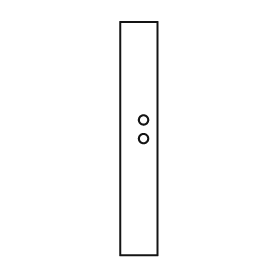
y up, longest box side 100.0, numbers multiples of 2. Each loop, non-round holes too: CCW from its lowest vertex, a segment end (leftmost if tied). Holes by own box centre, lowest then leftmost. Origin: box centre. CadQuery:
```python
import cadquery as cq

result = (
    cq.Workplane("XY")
    .moveTo(-8.0, -50.0)
    .lineTo(8.0, -50.0)
    .lineTo(8.0, 50.0)
    .lineTo(-8.0, 50.0)
    .close()
    .moveTo(2.0, 0.0)
    .circle(2.0)
    .moveTo(2.0, 8.0)
    .circle(2.0)
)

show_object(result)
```